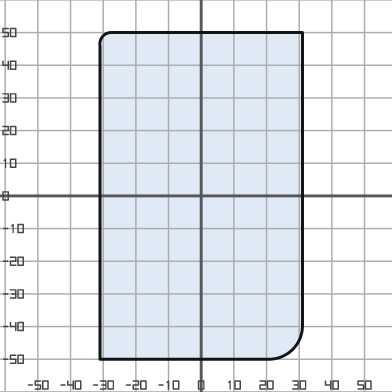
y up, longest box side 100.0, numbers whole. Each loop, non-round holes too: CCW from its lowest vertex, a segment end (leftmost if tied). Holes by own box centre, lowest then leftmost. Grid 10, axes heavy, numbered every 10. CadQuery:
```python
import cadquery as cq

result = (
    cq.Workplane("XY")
    .moveTo(-31.0, -50.0)
    .lineTo(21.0, -50.0)
    .threePointArc((28.0, -47.0), (31.0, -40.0))
    .lineTo(31.0, 50.0)
    .lineTo(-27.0, 50.0)
    .threePointArc((-30.0, 49.0), (-31.0, 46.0))
    .close()
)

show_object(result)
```